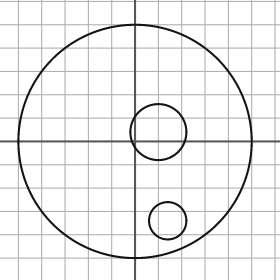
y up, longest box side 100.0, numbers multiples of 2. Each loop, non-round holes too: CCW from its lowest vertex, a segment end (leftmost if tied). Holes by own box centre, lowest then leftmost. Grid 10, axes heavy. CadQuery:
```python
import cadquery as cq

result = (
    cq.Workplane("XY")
    .moveTo(0.0, 0.0)
    .circle(50.0)
    .moveTo(14.0, -34.0)
    .circle(8.0)
    .moveTo(10.0, 4.0)
    .circle(12.0)
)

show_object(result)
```